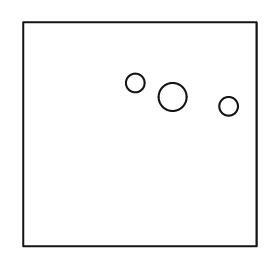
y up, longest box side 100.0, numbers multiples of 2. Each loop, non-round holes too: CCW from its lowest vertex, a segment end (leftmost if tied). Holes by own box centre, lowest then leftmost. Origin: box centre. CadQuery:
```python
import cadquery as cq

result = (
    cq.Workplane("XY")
    .moveTo(-50.0, -48.0)
    .lineTo(50.0, -48.0)
    .lineTo(50.0, 48.0)
    .lineTo(-50.0, 48.0)
    .close()
    .moveTo(38.0, 12.0)
    .circle(4.0)
    .moveTo(14.0, 16.0)
    .circle(6.0)
    .moveTo(-2.0, 22.0)
    .circle(4.0)
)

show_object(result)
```